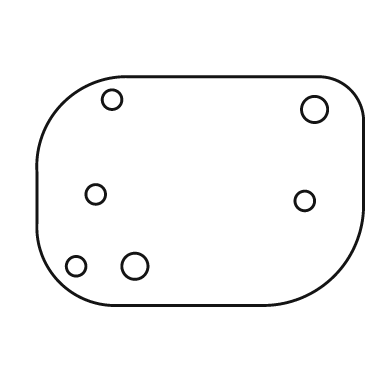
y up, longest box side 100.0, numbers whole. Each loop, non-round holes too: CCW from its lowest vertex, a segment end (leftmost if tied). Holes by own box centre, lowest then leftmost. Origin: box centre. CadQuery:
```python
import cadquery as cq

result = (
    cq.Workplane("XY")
    .moveTo(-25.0, -35.0)
    .lineTo(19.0, -35.0)
    .threePointArc((41.0, -26.0), (50.0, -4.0))
    .lineTo(50.0, 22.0)
    .threePointArc((46.0, 31.0), (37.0, 35.0))
    .lineTo(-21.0, 35.0)
    .threePointArc((-42.0, 27.0), (-50.0, 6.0))
    .lineTo(-50.0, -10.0)
    .threePointArc((-43.0, -28.0), (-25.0, -35.0))
    .close()
    .moveTo(-38.0, -23.0)
    .circle(3.0)
    .moveTo(-20.0, -23.0)
    .circle(4.0)
    .moveTo(32.0, -3.0)
    .circle(3.0)
    .moveTo(-32.0, -1.0)
    .circle(3.0)
    .moveTo(35.0, 25.0)
    .circle(4.0)
    .moveTo(-27.0, 28.0)
    .circle(3.0)
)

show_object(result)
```